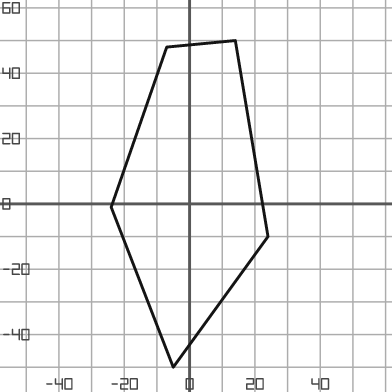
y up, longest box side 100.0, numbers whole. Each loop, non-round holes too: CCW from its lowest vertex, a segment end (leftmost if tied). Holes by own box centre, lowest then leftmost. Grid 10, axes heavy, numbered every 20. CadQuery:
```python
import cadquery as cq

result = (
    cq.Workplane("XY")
    .moveTo(-5.0, -50.0)
    .lineTo(24.0, -10.0)
    .lineTo(14.0, 50.0)
    .lineTo(-7.0, 48.0)
    .lineTo(-24.0, -1.0)
    .close()
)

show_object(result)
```